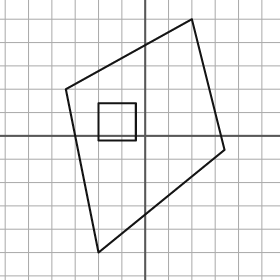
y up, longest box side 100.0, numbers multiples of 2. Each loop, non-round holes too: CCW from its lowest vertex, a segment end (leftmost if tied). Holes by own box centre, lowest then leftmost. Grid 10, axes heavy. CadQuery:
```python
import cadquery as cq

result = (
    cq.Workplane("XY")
    .moveTo(-20.0, -50.0)
    .lineTo(34.0, -6.0)
    .lineTo(20.0, 50.0)
    .lineTo(-34.0, 20.0)
    .close()
    .moveTo(-20.0, -2.0)
    .lineTo(-4.0, -2.0)
    .lineTo(-4.0, 14.0)
    .lineTo(-20.0, 14.0)
    .close()
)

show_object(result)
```